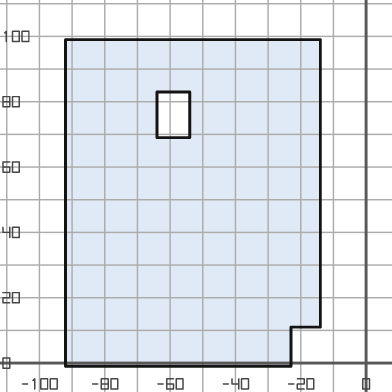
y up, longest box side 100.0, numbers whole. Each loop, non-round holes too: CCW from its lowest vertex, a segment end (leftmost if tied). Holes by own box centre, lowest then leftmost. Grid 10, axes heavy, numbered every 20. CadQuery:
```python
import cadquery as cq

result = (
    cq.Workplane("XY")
    .moveTo(-92.0, -1.0)
    .lineTo(-23.0, -1.0)
    .lineTo(-23.0, 11.0)
    .lineTo(-14.0, 11.0)
    .lineTo(-14.0, 99.0)
    .lineTo(-92.0, 99.0)
    .close()
    .moveTo(-64.0, 69.0)
    .lineTo(-54.0, 69.0)
    .lineTo(-54.0, 83.0)
    .lineTo(-64.0, 83.0)
    .close()
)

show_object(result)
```